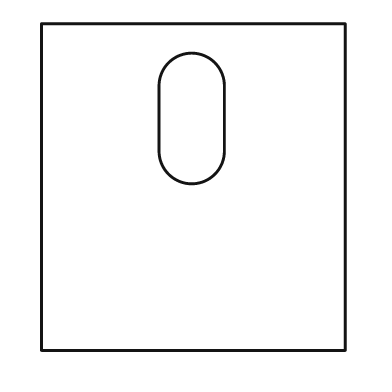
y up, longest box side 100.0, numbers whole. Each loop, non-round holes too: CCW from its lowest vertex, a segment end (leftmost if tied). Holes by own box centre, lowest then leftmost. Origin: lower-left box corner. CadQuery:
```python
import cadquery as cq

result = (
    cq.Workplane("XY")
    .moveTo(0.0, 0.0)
    .lineTo(93.0, 0.0)
    .lineTo(93.0, 100.0)
    .lineTo(0.0, 100.0)
    .close()
    .moveTo(36.0, 61.0)
    .threePointArc((46.0, 51.0), (56.0, 61.0))
    .lineTo(56.0, 81.0)
    .threePointArc((46.0, 91.0), (36.0, 81.0))
    .close()
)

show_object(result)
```